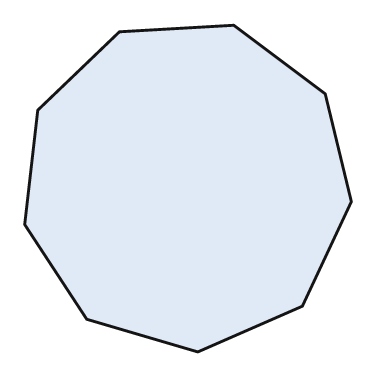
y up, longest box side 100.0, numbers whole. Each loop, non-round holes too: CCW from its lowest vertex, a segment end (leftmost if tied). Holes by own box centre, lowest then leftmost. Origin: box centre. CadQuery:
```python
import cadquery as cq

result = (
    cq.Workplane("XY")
    .moveTo(3.0, -50.0)
    .lineTo(35.0, -36.0)
    .lineTo(50.0, -4.0)
    .lineTo(42.0, 29.0)
    .lineTo(14.0, 50.0)
    .lineTo(-21.0, 48.0)
    .lineTo(-46.0, 24.0)
    .lineTo(-50.0, -11.0)
    .lineTo(-31.0, -40.0)
    .close()
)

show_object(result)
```